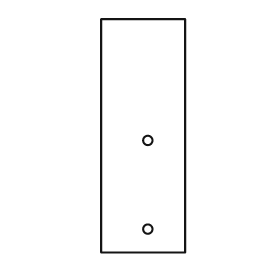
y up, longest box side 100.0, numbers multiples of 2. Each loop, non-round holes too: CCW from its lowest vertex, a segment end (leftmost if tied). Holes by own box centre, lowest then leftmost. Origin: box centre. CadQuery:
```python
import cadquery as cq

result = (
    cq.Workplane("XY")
    .moveTo(-18.0, -50.0)
    .lineTo(18.0, -50.0)
    .lineTo(18.0, 50.0)
    .lineTo(-18.0, 50.0)
    .close()
    .moveTo(2.0, -40.0)
    .circle(2.0)
    .moveTo(2.0, -2.0)
    .circle(2.0)
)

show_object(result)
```